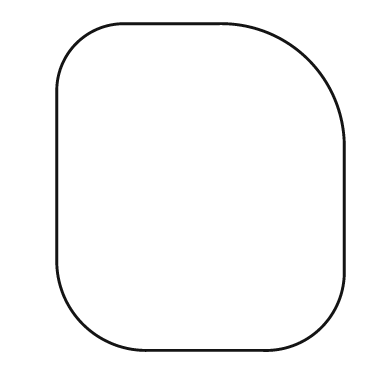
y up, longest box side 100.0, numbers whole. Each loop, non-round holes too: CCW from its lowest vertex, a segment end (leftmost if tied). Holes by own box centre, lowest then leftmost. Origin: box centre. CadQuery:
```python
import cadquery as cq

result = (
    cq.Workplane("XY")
    .moveTo(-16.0, -50.0)
    .lineTo(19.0, -50.0)
    .threePointArc((37.0, -43.0), (44.0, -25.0))
    .lineTo(44.0, 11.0)
    .threePointArc((33.0, 39.0), (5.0, 50.0))
    .lineTo(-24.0, 50.0)
    .threePointArc((-38.0, 44.0), (-44.0, 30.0))
    .lineTo(-44.0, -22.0)
    .threePointArc((-36.0, -42.0), (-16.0, -50.0))
    .close()
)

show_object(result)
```